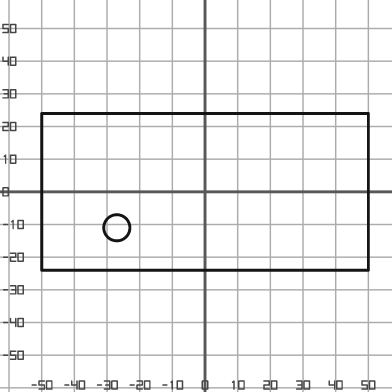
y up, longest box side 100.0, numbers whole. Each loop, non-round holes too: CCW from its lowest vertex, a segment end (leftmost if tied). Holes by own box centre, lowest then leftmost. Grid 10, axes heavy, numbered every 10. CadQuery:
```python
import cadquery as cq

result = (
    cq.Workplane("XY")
    .moveTo(-50.0, -24.0)
    .lineTo(50.0, -24.0)
    .lineTo(50.0, 24.0)
    .lineTo(-50.0, 24.0)
    .close()
    .moveTo(-27.0, -11.0)
    .circle(4.0)
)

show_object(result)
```